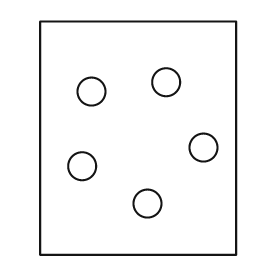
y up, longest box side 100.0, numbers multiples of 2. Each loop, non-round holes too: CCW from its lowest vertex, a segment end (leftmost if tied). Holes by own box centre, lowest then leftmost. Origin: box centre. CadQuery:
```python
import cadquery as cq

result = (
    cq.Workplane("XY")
    .moveTo(-42.0, -50.0)
    .lineTo(42.0, -50.0)
    .lineTo(42.0, 50.0)
    .lineTo(-42.0, 50.0)
    .close()
    .moveTo(4.0, -28.0)
    .circle(6.0)
    .moveTo(-24.0, -12.0)
    .circle(6.0)
    .moveTo(28.0, -4.0)
    .circle(6.0)
    .moveTo(-20.0, 20.0)
    .circle(6.0)
    .moveTo(12.0, 24.0)
    .circle(6.0)
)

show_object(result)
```